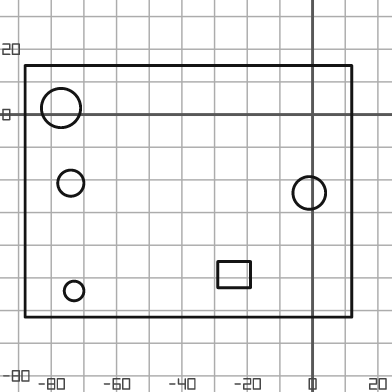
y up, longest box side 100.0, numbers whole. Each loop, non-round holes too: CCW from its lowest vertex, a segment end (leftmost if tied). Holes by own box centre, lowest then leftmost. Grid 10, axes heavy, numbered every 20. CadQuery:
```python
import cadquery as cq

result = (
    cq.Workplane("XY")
    .moveTo(-88.0, -62.0)
    .lineTo(12.0, -62.0)
    .lineTo(12.0, 15.0)
    .lineTo(-88.0, 15.0)
    .close()
    .moveTo(-73.0, -54.0)
    .circle(3.0)
    .moveTo(-29.0, -53.0)
    .lineTo(-19.0, -53.0)
    .lineTo(-19.0, -45.0)
    .lineTo(-29.0, -45.0)
    .close()
    .moveTo(-1.0, -24.0)
    .circle(5.0)
    .moveTo(-74.0, -21.0)
    .circle(4.0)
    .moveTo(-77.0, 2.0)
    .circle(6.0)
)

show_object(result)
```